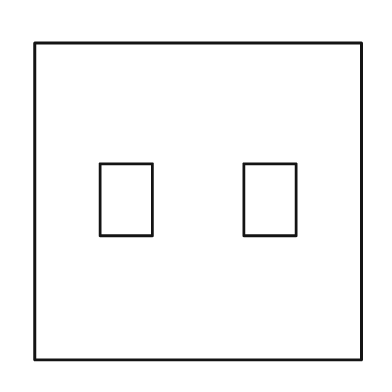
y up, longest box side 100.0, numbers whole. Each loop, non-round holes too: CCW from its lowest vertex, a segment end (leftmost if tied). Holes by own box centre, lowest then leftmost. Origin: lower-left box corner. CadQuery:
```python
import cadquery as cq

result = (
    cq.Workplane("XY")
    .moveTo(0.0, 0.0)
    .lineTo(100.0, 0.0)
    .lineTo(100.0, 97.0)
    .lineTo(0.0, 97.0)
    .close()
    .moveTo(20.0, 38.0)
    .lineTo(36.0, 38.0)
    .lineTo(36.0, 60.0)
    .lineTo(20.0, 60.0)
    .close()
    .moveTo(64.0, 38.0)
    .lineTo(80.0, 38.0)
    .lineTo(80.0, 60.0)
    .lineTo(64.0, 60.0)
    .close()
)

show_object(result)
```